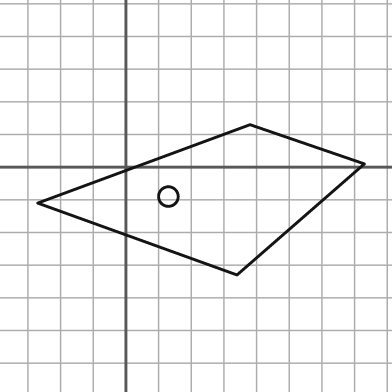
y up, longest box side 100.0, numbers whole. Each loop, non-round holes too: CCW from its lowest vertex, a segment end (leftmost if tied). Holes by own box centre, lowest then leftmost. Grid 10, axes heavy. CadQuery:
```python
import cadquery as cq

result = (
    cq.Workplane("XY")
    .moveTo(34.0, -33.0)
    .lineTo(73.0, 1.0)
    .lineTo(38.0, 13.0)
    .lineTo(-27.0, -11.0)
    .close()
    .moveTo(13.0, -9.0)
    .circle(3.0)
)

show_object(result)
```